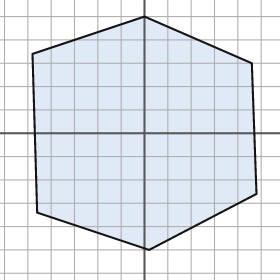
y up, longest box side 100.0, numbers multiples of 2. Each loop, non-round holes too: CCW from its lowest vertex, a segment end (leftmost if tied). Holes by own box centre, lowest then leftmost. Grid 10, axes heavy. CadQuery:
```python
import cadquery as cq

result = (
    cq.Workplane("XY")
    .moveTo(2.0, -50.0)
    .lineTo(48.0, -26.0)
    .lineTo(46.0, 30.0)
    .lineTo(0.0, 50.0)
    .lineTo(-48.0, 34.0)
    .lineTo(-46.0, -34.0)
    .close()
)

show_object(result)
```